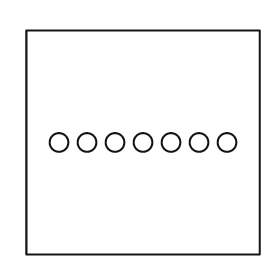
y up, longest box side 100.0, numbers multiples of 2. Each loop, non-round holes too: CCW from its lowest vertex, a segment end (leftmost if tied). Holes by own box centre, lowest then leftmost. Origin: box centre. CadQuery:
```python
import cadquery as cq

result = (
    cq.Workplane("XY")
    .moveTo(-50.0, -48.0)
    .lineTo(50.0, -48.0)
    .lineTo(50.0, 48.0)
    .lineTo(-50.0, 48.0)
    .close()
    .moveTo(-36.0, 0.0)
    .circle(4.0)
    .moveTo(-24.0, 0.0)
    .circle(4.0)
    .moveTo(-12.0, 0.0)
    .circle(4.0)
    .moveTo(0.0, 0.0)
    .circle(4.0)
    .moveTo(12.0, 0.0)
    .circle(4.0)
    .moveTo(24.0, 0.0)
    .circle(4.0)
    .moveTo(36.0, 0.0)
    .circle(4.0)
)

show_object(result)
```